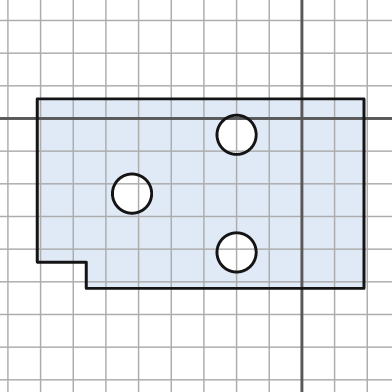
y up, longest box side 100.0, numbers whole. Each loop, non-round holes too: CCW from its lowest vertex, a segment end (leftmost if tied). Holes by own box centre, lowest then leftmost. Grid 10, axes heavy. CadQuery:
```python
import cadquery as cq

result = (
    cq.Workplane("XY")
    .moveTo(-66.0, -52.0)
    .lineTo(19.0, -52.0)
    .lineTo(19.0, 6.0)
    .lineTo(-81.0, 6.0)
    .lineTo(-81.0, -44.0)
    .lineTo(-66.0, -44.0)
    .close()
    .moveTo(-20.0, -41.0)
    .circle(6.0)
    .moveTo(-52.0, -23.0)
    .circle(6.0)
    .moveTo(-20.0, -5.0)
    .circle(6.0)
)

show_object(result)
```